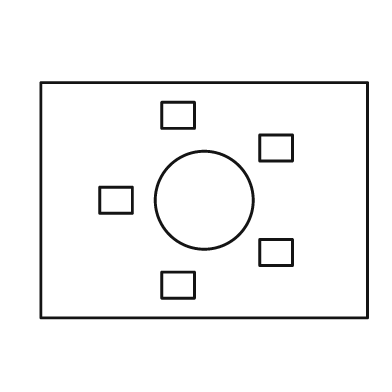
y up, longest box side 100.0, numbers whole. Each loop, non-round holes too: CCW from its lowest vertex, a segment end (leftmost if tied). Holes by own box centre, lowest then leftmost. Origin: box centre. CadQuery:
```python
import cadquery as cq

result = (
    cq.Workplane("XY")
    .moveTo(-50.0, -36.0)
    .lineTo(50.0, -36.0)
    .lineTo(50.0, 36.0)
    .lineTo(-50.0, 36.0)
    .close()
    .moveTo(-13.0, -30.0)
    .lineTo(-3.0, -30.0)
    .lineTo(-3.0, -22.0)
    .lineTo(-13.0, -22.0)
    .close()
    .moveTo(17.0, -20.0)
    .lineTo(27.0, -20.0)
    .lineTo(27.0, -12.0)
    .lineTo(17.0, -12.0)
    .close()
    .moveTo(-32.0, -4.0)
    .lineTo(-22.0, -4.0)
    .lineTo(-22.0, 4.0)
    .lineTo(-32.0, 4.0)
    .close()
    .moveTo(0.0, 0.0)
    .circle(15.0)
    .moveTo(17.0, 12.0)
    .lineTo(27.0, 12.0)
    .lineTo(27.0, 20.0)
    .lineTo(17.0, 20.0)
    .close()
    .moveTo(-13.0, 22.0)
    .lineTo(-3.0, 22.0)
    .lineTo(-3.0, 30.0)
    .lineTo(-13.0, 30.0)
    .close()
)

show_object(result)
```